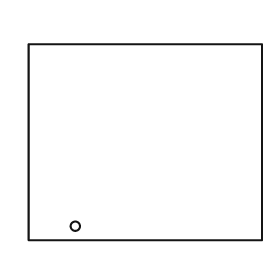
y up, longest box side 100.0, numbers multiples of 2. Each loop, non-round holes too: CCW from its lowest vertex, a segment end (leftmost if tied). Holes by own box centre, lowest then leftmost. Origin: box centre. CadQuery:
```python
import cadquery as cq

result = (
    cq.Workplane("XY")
    .moveTo(-50.0, -42.0)
    .lineTo(50.0, -42.0)
    .lineTo(50.0, 42.0)
    .lineTo(-50.0, 42.0)
    .close()
    .moveTo(-30.0, -36.0)
    .circle(2.0)
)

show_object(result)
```